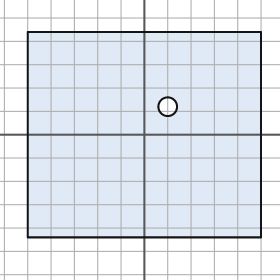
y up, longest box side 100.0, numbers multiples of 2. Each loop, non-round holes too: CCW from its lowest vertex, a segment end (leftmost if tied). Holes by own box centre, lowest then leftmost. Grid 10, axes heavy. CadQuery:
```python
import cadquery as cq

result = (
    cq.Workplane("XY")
    .moveTo(-50.0, -44.0)
    .lineTo(50.0, -44.0)
    .lineTo(50.0, 44.0)
    .lineTo(-50.0, 44.0)
    .close()
    .moveTo(10.0, 12.0)
    .circle(4.0)
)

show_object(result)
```